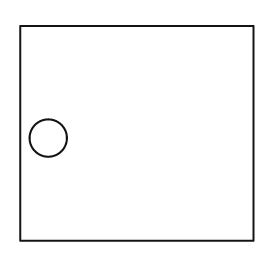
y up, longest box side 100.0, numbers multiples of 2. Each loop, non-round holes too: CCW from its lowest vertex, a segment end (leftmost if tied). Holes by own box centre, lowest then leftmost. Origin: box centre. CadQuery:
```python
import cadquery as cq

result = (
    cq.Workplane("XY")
    .moveTo(-50.0, -46.0)
    .lineTo(50.0, -46.0)
    .lineTo(50.0, 46.0)
    .lineTo(-50.0, 46.0)
    .close()
    .moveTo(-38.0, -2.0)
    .circle(8.0)
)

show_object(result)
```